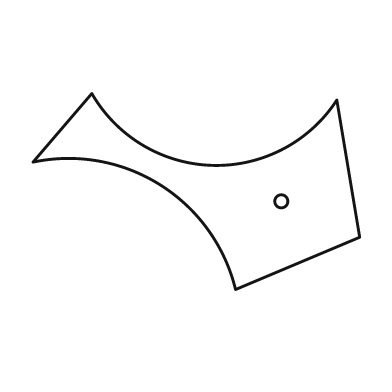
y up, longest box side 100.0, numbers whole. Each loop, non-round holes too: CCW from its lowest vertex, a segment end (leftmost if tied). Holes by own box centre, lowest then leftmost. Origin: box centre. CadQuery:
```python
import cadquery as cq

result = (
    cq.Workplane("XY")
    .moveTo(12.0, -30.0)
    .lineTo(50.0, -14.0)
    .lineTo(43.0, 28.0)
    .threePointArc((5.0, 8.0), (-32.0, 30.0))
    .lineTo(-50.0, 9.0)
    .threePointArc((-11.0, 2.0), (12.0, -30.0))
    .close()
    .moveTo(26.0, -3.0)
    .circle(2.0)
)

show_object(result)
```